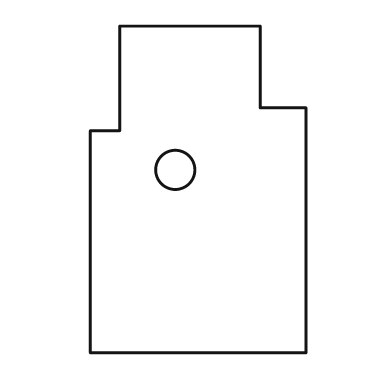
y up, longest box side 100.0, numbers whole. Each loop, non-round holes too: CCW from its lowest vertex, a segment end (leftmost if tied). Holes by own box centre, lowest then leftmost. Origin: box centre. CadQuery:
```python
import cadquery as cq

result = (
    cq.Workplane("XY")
    .moveTo(-33.0, -50.0)
    .lineTo(33.0, -50.0)
    .lineTo(33.0, 25.0)
    .lineTo(19.0, 25.0)
    .lineTo(19.0, 50.0)
    .lineTo(-24.0, 50.0)
    .lineTo(-24.0, 18.0)
    .lineTo(-33.0, 18.0)
    .close()
    .moveTo(-7.0, 6.0)
    .circle(6.0)
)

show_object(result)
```